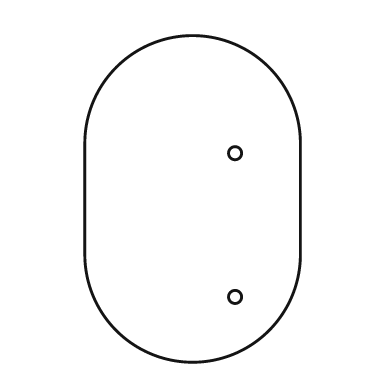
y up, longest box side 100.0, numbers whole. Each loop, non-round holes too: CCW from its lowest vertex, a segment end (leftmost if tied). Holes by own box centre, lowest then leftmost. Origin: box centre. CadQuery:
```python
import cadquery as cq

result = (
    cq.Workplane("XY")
    .moveTo(-33.0, -17.0)
    .threePointArc((0.0, -50.0), (33.0, -17.0))
    .lineTo(33.0, 17.0)
    .threePointArc((0.0, 50.0), (-33.0, 17.0))
    .close()
    .moveTo(13.0, -30.0)
    .circle(2.0)
    .moveTo(13.0, 14.0)
    .circle(2.0)
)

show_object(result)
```